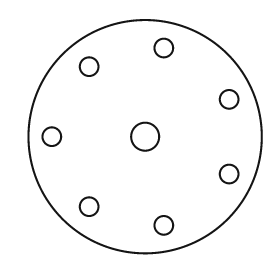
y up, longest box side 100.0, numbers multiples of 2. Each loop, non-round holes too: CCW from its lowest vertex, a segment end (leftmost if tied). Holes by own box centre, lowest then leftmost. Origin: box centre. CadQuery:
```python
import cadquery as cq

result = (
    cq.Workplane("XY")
    .moveTo(0.0, 0.0)
    .circle(50.0)
    .moveTo(8.0, -38.0)
    .circle(4.0)
    .moveTo(-24.0, -30.0)
    .circle(4.0)
    .moveTo(36.0, -16.0)
    .circle(4.0)
    .moveTo(-40.0, 0.0)
    .circle(4.0)
    .moveTo(0.0, 0.0)
    .circle(6.0)
    .moveTo(36.0, 16.0)
    .circle(4.0)
    .moveTo(-24.0, 30.0)
    .circle(4.0)
    .moveTo(8.0, 38.0)
    .circle(4.0)
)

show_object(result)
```